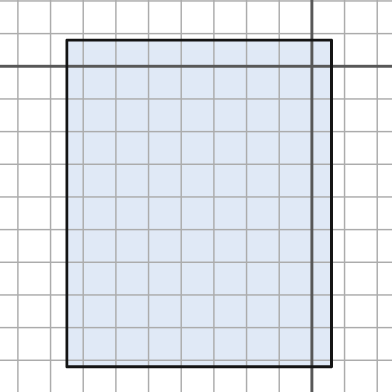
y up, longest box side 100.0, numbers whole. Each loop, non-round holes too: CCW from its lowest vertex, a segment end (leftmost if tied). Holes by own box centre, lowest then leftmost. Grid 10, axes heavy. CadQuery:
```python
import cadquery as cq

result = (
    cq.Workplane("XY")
    .moveTo(-75.0, -92.0)
    .lineTo(6.0, -92.0)
    .lineTo(6.0, 8.0)
    .lineTo(-75.0, 8.0)
    .close()
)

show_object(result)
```